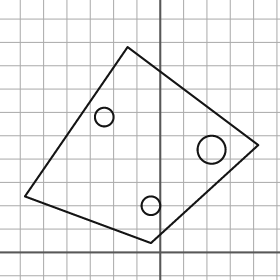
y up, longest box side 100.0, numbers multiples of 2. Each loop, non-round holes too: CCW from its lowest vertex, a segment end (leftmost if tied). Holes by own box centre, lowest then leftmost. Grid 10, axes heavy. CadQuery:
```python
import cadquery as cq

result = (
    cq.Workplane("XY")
    .moveTo(-4.0, 4.0)
    .lineTo(42.0, 46.0)
    .lineTo(-14.0, 88.0)
    .lineTo(-58.0, 24.0)
    .close()
    .moveTo(-4.0, 20.0)
    .circle(4.0)
    .moveTo(22.0, 44.0)
    .circle(6.0)
    .moveTo(-24.0, 58.0)
    .circle(4.0)
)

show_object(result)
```